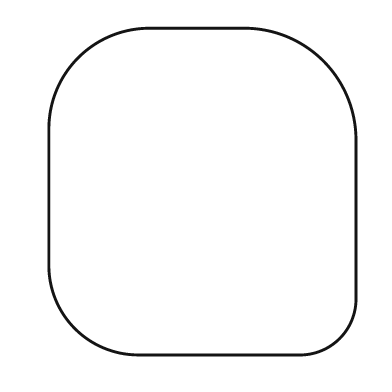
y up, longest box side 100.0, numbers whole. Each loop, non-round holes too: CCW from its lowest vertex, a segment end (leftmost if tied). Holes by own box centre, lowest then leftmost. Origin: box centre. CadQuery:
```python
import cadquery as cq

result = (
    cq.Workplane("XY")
    .moveTo(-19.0, -50.0)
    .lineTo(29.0, -50.0)
    .threePointArc((42.0, -45.0), (47.0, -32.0))
    .lineTo(47.0, 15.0)
    .threePointArc((37.0, 40.0), (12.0, 50.0))
    .lineTo(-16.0, 50.0)
    .threePointArc((-38.0, 41.0), (-47.0, 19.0))
    .lineTo(-47.0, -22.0)
    .threePointArc((-39.0, -42.0), (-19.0, -50.0))
    .close()
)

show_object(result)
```